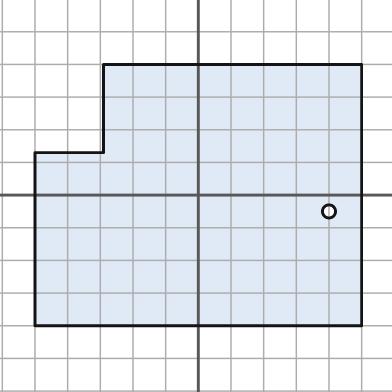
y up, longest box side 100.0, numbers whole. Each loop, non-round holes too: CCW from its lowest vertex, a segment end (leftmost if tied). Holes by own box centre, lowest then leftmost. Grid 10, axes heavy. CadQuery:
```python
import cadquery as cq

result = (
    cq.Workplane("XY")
    .moveTo(-50.0, -40.0)
    .lineTo(50.0, -40.0)
    .lineTo(50.0, 40.0)
    .lineTo(-29.0, 40.0)
    .lineTo(-29.0, 13.0)
    .lineTo(-50.0, 13.0)
    .close()
    .moveTo(40.0, -5.0)
    .circle(2.0)
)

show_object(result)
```